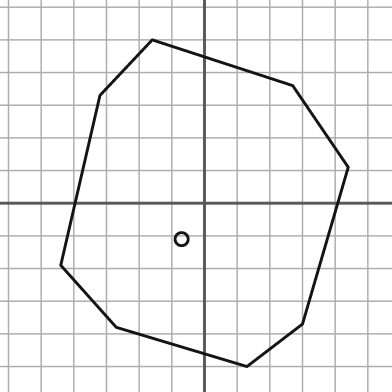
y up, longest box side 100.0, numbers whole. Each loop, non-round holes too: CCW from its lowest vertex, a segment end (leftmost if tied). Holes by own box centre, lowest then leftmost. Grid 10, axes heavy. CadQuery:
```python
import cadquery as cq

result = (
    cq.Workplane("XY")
    .moveTo(13.0, -50.0)
    .lineTo(30.0, -37.0)
    .lineTo(44.0, 11.0)
    .lineTo(27.0, 36.0)
    .lineTo(-16.0, 50.0)
    .lineTo(-32.0, 33.0)
    .lineTo(-44.0, -19.0)
    .lineTo(-27.0, -38.0)
    .close()
    .moveTo(-7.0, -11.0)
    .circle(2.0)
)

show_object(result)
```